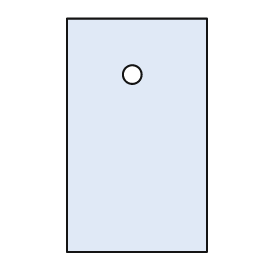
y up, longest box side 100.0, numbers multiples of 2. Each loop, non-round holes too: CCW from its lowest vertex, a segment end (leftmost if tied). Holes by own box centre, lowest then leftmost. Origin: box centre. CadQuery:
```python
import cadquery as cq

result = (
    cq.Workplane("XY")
    .moveTo(-30.0, -50.0)
    .lineTo(30.0, -50.0)
    .lineTo(30.0, 50.0)
    .lineTo(-30.0, 50.0)
    .close()
    .moveTo(-2.0, 26.0)
    .circle(4.0)
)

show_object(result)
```